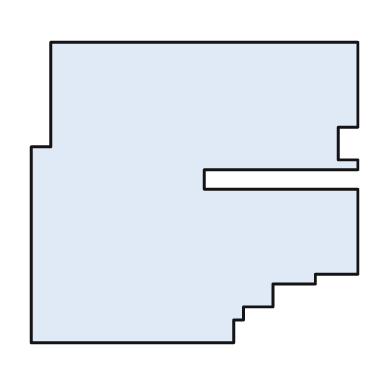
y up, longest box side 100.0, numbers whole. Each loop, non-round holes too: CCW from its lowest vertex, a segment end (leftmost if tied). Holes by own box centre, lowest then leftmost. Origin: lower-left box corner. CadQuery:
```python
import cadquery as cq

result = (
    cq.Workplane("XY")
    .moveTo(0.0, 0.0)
    .lineTo(62.0, 0.0)
    .lineTo(62.0, 7.0)
    .lineTo(65.0, 7.0)
    .lineTo(65.0, 11.0)
    .lineTo(74.0, 11.0)
    .lineTo(74.0, 18.0)
    .lineTo(87.0, 18.0)
    .lineTo(87.0, 21.0)
    .lineTo(100.0, 21.0)
    .lineTo(100.0, 47.0)
    .lineTo(53.0, 47.0)
    .lineTo(53.0, 53.0)
    .lineTo(100.0, 53.0)
    .lineTo(100.0, 56.0)
    .lineTo(94.0, 56.0)
    .lineTo(94.0, 66.0)
    .lineTo(100.0, 66.0)
    .lineTo(100.0, 92.0)
    .lineTo(6.0, 92.0)
    .lineTo(6.0, 60.0)
    .lineTo(0.0, 60.0)
    .close()
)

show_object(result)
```